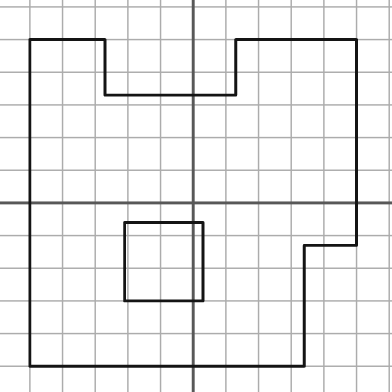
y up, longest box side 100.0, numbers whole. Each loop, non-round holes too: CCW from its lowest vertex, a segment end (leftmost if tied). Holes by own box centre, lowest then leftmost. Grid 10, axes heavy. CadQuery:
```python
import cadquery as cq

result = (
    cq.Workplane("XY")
    .moveTo(-50.0, -50.0)
    .lineTo(34.0, -50.0)
    .lineTo(34.0, -13.0)
    .lineTo(50.0, -13.0)
    .lineTo(50.0, 50.0)
    .lineTo(13.0, 50.0)
    .lineTo(13.0, 33.0)
    .lineTo(-27.0, 33.0)
    .lineTo(-27.0, 50.0)
    .lineTo(-50.0, 50.0)
    .close()
    .moveTo(-21.0, -30.0)
    .lineTo(3.0, -30.0)
    .lineTo(3.0, -6.0)
    .lineTo(-21.0, -6.0)
    .close()
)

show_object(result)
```